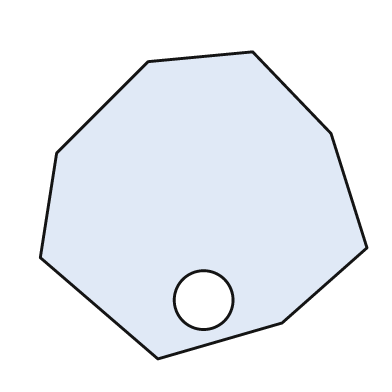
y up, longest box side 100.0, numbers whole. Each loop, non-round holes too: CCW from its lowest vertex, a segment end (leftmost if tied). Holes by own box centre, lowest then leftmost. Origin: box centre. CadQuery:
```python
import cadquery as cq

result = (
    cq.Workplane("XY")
    .moveTo(-14.0, -47.0)
    .lineTo(24.0, -36.0)
    .lineTo(50.0, -13.0)
    .lineTo(39.0, 22.0)
    .lineTo(15.0, 47.0)
    .lineTo(-17.0, 44.0)
    .lineTo(-45.0, 16.0)
    .lineTo(-50.0, -16.0)
    .close()
    .moveTo(0.0, -29.0)
    .circle(9.0)
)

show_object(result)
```